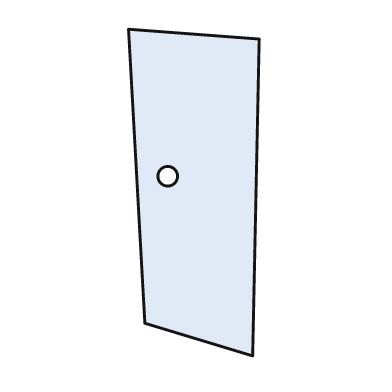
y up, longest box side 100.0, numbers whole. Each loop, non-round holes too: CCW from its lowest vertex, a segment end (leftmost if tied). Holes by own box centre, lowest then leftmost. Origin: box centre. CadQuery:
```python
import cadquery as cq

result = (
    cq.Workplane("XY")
    .moveTo(18.0, -50.0)
    .lineTo(20.0, 47.0)
    .lineTo(-20.0, 50.0)
    .lineTo(-15.0, -40.0)
    .close()
    .moveTo(-8.0, 5.0)
    .circle(3.0)
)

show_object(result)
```